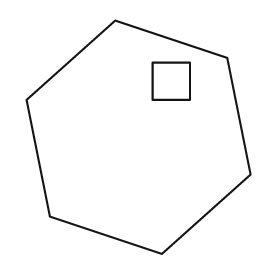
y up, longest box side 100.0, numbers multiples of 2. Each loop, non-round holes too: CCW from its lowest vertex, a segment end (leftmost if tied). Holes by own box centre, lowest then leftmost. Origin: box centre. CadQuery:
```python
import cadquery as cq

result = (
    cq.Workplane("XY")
    .moveTo(10.0, -50.0)
    .lineTo(48.0, -16.0)
    .lineTo(38.0, 34.0)
    .lineTo(-10.0, 50.0)
    .lineTo(-48.0, 16.0)
    .lineTo(-38.0, -34.0)
    .close()
    .moveTo(6.0, 16.0)
    .lineTo(22.0, 16.0)
    .lineTo(22.0, 32.0)
    .lineTo(6.0, 32.0)
    .close()
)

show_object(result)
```